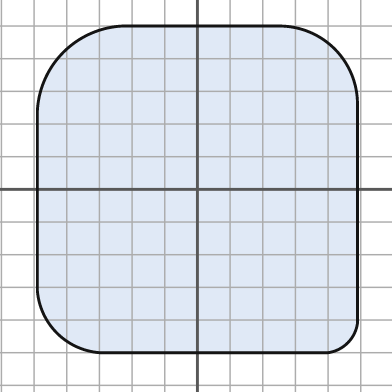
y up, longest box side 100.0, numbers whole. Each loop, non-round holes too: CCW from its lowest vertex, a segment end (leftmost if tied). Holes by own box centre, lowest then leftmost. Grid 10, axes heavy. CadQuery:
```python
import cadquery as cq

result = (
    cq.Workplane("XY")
    .moveTo(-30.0, -50.0)
    .lineTo(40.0, -50.0)
    .threePointArc((46.0, -47.0), (49.0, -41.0))
    .lineTo(49.0, 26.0)
    .threePointArc((42.0, 43.0), (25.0, 50.0))
    .lineTo(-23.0, 50.0)
    .threePointArc((-41.0, 42.0), (-49.0, 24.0))
    .lineTo(-49.0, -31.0)
    .threePointArc((-43.0, -44.0), (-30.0, -50.0))
    .close()
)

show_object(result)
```